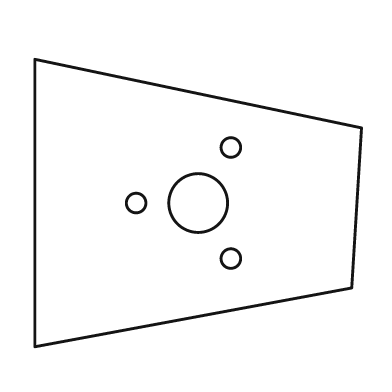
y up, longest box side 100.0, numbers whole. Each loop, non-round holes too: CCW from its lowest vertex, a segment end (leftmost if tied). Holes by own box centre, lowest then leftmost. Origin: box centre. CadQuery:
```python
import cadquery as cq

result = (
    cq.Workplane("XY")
    .moveTo(-50.0, -44.0)
    .lineTo(47.0, -26.0)
    .lineTo(50.0, 23.0)
    .lineTo(-50.0, 44.0)
    .close()
    .moveTo(10.0, -17.0)
    .circle(3.0)
    .moveTo(-19.0, 0.0)
    .circle(3.0)
    .moveTo(0.0, 0.0)
    .circle(9.0)
    .moveTo(10.0, 17.0)
    .circle(3.0)
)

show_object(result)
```